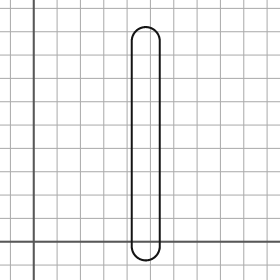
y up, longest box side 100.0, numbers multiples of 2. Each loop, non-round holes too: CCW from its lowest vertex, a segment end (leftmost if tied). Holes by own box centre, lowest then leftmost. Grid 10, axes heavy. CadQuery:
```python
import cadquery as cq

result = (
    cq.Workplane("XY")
    .moveTo(42.0, -2.0)
    .threePointArc((48.0, -8.0), (54.0, -2.0))
    .lineTo(54.0, 86.0)
    .threePointArc((48.0, 92.0), (42.0, 86.0))
    .close()
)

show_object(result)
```